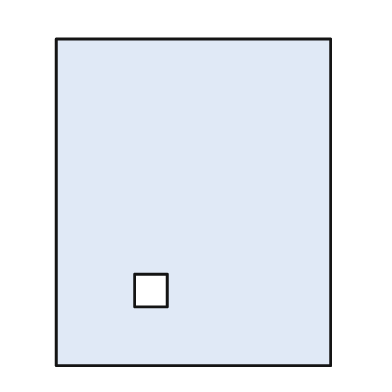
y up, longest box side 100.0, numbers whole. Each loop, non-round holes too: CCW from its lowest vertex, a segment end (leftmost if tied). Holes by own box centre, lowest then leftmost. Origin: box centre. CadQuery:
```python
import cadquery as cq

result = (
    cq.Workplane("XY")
    .moveTo(-42.0, -50.0)
    .lineTo(42.0, -50.0)
    .lineTo(42.0, 50.0)
    .lineTo(-42.0, 50.0)
    .close()
    .moveTo(-18.0, -32.0)
    .lineTo(-8.0, -32.0)
    .lineTo(-8.0, -22.0)
    .lineTo(-18.0, -22.0)
    .close()
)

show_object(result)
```